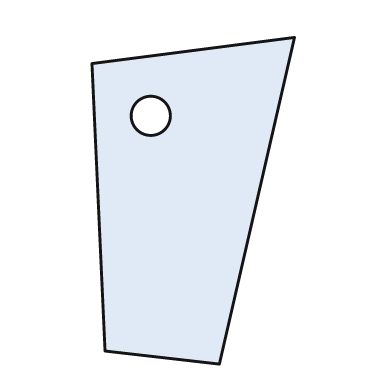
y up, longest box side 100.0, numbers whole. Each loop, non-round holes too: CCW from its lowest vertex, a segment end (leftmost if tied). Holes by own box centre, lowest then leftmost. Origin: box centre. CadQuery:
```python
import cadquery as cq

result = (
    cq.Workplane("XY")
    .moveTo(8.0, -50.0)
    .lineTo(31.0, 50.0)
    .lineTo(-31.0, 42.0)
    .lineTo(-27.0, -46.0)
    .close()
    .moveTo(-13.0, 26.0)
    .circle(6.0)
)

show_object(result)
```